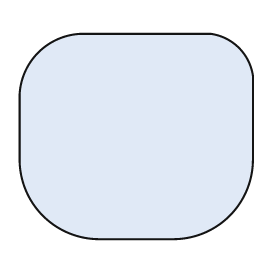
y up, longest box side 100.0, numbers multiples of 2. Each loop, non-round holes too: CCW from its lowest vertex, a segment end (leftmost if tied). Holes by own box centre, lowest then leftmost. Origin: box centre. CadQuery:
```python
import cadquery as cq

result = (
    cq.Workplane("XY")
    .moveTo(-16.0, -44.0)
    .lineTo(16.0, -44.0)
    .threePointArc((40.0, -34.0), (50.0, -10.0))
    .lineTo(50.0, 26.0)
    .threePointArc((44.0, 38.0), (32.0, 44.0))
    .lineTo(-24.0, 44.0)
    .threePointArc((-42.0, 36.0), (-50.0, 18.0))
    .lineTo(-50.0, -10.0)
    .threePointArc((-40.0, -34.0), (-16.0, -44.0))
    .close()
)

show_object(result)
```